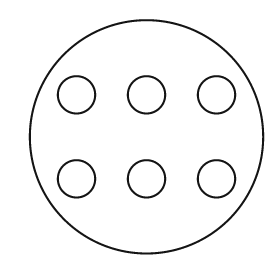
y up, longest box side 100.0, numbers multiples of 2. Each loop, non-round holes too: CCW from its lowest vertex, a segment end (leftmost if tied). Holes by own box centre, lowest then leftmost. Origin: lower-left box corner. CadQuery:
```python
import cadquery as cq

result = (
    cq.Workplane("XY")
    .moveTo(50.0, 50.0)
    .circle(50.0)
    .moveTo(20.0, 32.0)
    .circle(8.0)
    .moveTo(50.0, 32.0)
    .circle(8.0)
    .moveTo(80.0, 32.0)
    .circle(8.0)
    .moveTo(20.0, 68.0)
    .circle(8.0)
    .moveTo(50.0, 68.0)
    .circle(8.0)
    .moveTo(80.0, 68.0)
    .circle(8.0)
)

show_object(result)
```